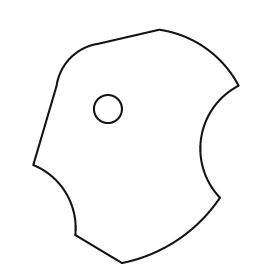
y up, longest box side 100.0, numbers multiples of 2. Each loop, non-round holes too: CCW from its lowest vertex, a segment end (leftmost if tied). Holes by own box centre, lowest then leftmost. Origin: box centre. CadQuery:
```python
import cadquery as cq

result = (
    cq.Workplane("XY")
    .moveTo(-6.0, -50.0)
    .threePointArc((18.0, -40.0), (36.0, -22.0))
    .threePointArc((28.0, 4.0), (44.0, 26.0))
    .threePointArc((30.0, 42.0), (10.0, 50.0))
    .lineTo(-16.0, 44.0)
    .threePointArc((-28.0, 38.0), (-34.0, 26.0))
    .lineTo(-44.0, -8.0)
    .threePointArc((-30.0, -20.0), (-26.0, -38.0))
    .close()
    .moveTo(-12.0, 16.0)
    .circle(6.0)
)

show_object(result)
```